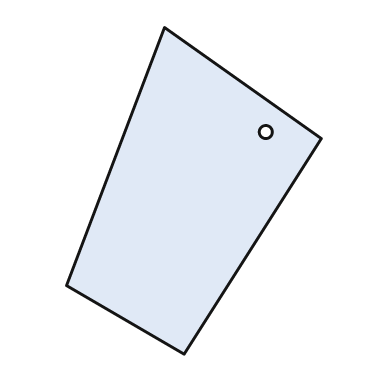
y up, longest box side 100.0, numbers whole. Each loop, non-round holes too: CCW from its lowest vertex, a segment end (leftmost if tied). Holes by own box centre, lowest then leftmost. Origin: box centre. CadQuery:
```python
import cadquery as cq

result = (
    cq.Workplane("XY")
    .moveTo(-3.0, -50.0)
    .lineTo(39.0, 16.0)
    .lineTo(-9.0, 50.0)
    .lineTo(-39.0, -29.0)
    .close()
    .moveTo(22.0, 18.0)
    .circle(2.0)
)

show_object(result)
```